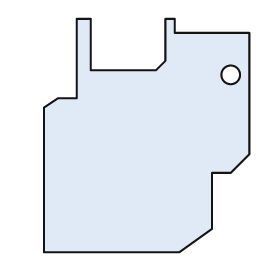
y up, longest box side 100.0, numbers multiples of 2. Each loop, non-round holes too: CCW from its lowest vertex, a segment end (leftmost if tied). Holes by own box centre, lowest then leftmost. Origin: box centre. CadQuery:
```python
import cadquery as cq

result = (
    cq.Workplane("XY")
    .moveTo(-44.0, -50.0)
    .lineTo(14.0, -50.0)
    .lineTo(28.0, -40.0)
    .lineTo(28.0, -16.0)
    .lineTo(36.0, -16.0)
    .lineTo(44.0, -8.0)
    .lineTo(44.0, 44.0)
    .lineTo(12.0, 44.0)
    .lineTo(12.0, 50.0)
    .lineTo(8.0, 50.0)
    .lineTo(8.0, 32.0)
    .lineTo(4.0, 28.0)
    .lineTo(-24.0, 28.0)
    .lineTo(-24.0, 50.0)
    .lineTo(-30.0, 50.0)
    .lineTo(-30.0, 16.0)
    .lineTo(-38.0, 16.0)
    .lineTo(-44.0, 12.0)
    .close()
    .moveTo(36.0, 26.0)
    .circle(4.0)
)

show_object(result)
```